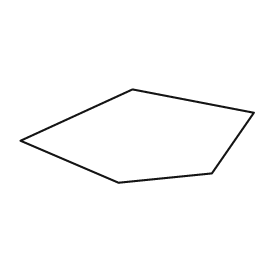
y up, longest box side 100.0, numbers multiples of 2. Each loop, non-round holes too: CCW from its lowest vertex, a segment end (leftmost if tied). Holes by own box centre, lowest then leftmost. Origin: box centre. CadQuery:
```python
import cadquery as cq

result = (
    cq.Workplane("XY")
    .moveTo(-8.0, -20.0)
    .lineTo(32.0, -16.0)
    .lineTo(50.0, 10.0)
    .lineTo(-2.0, 20.0)
    .lineTo(-50.0, -2.0)
    .close()
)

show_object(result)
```